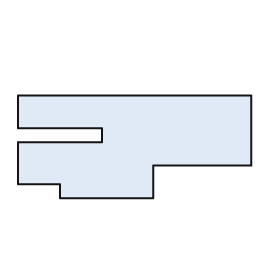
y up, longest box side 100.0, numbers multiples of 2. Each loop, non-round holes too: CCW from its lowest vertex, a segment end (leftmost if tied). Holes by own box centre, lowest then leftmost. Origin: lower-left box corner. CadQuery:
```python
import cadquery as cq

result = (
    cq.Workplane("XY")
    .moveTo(18.0, 0.0)
    .lineTo(58.0, 0.0)
    .lineTo(58.0, 14.0)
    .lineTo(100.0, 14.0)
    .lineTo(100.0, 44.0)
    .lineTo(0.0, 44.0)
    .lineTo(0.0, 30.0)
    .lineTo(36.0, 30.0)
    .lineTo(36.0, 24.0)
    .lineTo(0.0, 24.0)
    .lineTo(0.0, 6.0)
    .lineTo(18.0, 6.0)
    .close()
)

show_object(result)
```